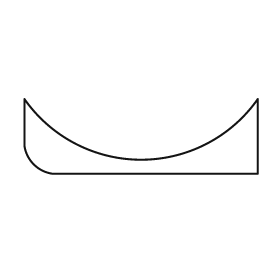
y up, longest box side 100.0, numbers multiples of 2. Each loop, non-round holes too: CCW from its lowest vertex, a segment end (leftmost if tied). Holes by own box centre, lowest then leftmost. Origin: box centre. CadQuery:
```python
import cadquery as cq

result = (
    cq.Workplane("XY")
    .moveTo(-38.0, -16.0)
    .lineTo(50.0, -16.0)
    .lineTo(50.0, 16.0)
    .threePointArc((0.0, -10.0), (-50.0, 16.0))
    .lineTo(-50.0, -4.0)
    .threePointArc((-46.0, -12.0), (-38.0, -16.0))
    .close()
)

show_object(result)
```